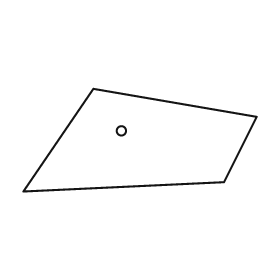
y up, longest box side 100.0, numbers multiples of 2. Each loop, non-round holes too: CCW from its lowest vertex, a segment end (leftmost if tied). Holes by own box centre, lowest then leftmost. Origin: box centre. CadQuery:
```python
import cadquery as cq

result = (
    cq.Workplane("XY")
    .moveTo(-50.0, -22.0)
    .lineTo(36.0, -18.0)
    .lineTo(50.0, 10.0)
    .lineTo(-20.0, 22.0)
    .close()
    .moveTo(-8.0, 4.0)
    .circle(2.0)
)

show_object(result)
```